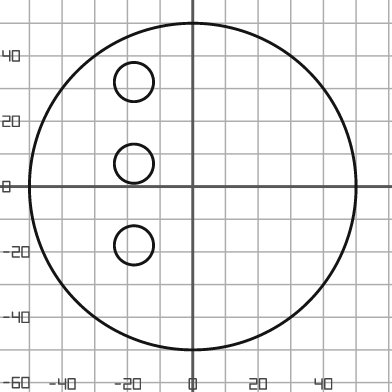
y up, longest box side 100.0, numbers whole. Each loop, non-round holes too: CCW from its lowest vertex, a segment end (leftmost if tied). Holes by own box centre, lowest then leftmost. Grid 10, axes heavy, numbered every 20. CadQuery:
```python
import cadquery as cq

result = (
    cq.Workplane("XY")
    .moveTo(0.0, 0.0)
    .circle(50.0)
    .moveTo(-18.0, -18.0)
    .circle(6.0)
    .moveTo(-18.0, 7.0)
    .circle(6.0)
    .moveTo(-18.0, 32.0)
    .circle(6.0)
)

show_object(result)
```